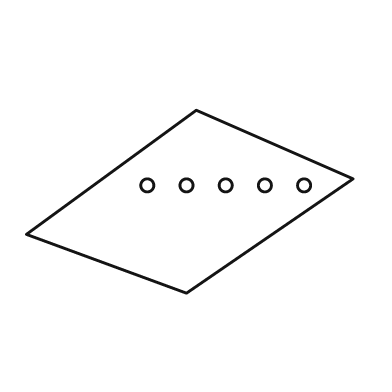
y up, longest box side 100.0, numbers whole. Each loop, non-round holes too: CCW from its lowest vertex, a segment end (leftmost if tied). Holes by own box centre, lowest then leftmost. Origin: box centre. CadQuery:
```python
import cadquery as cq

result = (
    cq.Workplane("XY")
    .moveTo(-1.0, -28.0)
    .lineTo(50.0, 7.0)
    .lineTo(2.0, 28.0)
    .lineTo(-50.0, -10.0)
    .close()
    .moveTo(-13.0, 5.0)
    .circle(2.0)
    .moveTo(-1.0, 5.0)
    .circle(2.0)
    .moveTo(11.0, 5.0)
    .circle(2.0)
    .moveTo(23.0, 5.0)
    .circle(2.0)
    .moveTo(35.0, 5.0)
    .circle(2.0)
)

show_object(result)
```